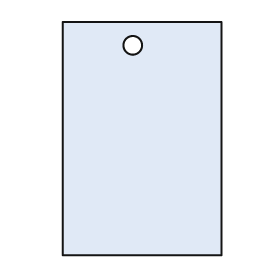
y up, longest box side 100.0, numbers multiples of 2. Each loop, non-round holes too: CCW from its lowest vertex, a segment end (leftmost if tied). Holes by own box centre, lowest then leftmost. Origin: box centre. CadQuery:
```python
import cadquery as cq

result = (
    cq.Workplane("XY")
    .moveTo(-34.0, -50.0)
    .lineTo(34.0, -50.0)
    .lineTo(34.0, 50.0)
    .lineTo(-34.0, 50.0)
    .close()
    .moveTo(-4.0, 40.0)
    .circle(4.0)
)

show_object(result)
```